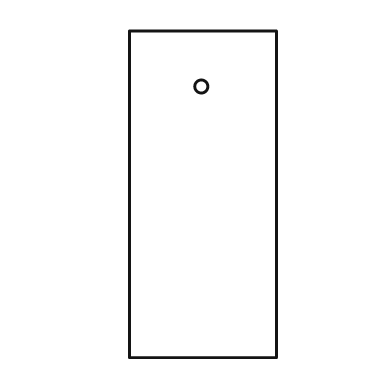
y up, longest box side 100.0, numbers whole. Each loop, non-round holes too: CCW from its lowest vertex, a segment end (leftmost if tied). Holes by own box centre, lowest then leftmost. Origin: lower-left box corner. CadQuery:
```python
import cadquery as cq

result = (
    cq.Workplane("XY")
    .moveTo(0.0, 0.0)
    .lineTo(45.0, 0.0)
    .lineTo(45.0, 100.0)
    .lineTo(0.0, 100.0)
    .close()
    .moveTo(22.0, 83.0)
    .circle(2.0)
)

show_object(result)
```